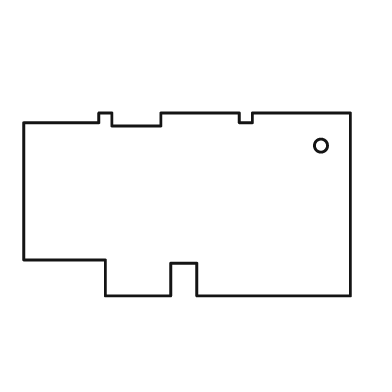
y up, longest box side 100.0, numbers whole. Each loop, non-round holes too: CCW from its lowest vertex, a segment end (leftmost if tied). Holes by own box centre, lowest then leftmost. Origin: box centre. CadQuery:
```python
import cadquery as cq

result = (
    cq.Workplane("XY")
    .moveTo(-25.0, -28.0)
    .lineTo(-5.0, -28.0)
    .lineTo(-5.0, -18.0)
    .lineTo(3.0, -18.0)
    .lineTo(3.0, -28.0)
    .lineTo(50.0, -28.0)
    .lineTo(50.0, 28.0)
    .lineTo(20.0, 28.0)
    .lineTo(20.0, 25.0)
    .lineTo(16.0, 25.0)
    .lineTo(16.0, 28.0)
    .lineTo(-8.0, 28.0)
    .lineTo(-8.0, 24.0)
    .lineTo(-23.0, 24.0)
    .lineTo(-23.0, 28.0)
    .lineTo(-27.0, 28.0)
    .lineTo(-27.0, 25.0)
    .lineTo(-50.0, 25.0)
    .lineTo(-50.0, -17.0)
    .lineTo(-25.0, -17.0)
    .close()
    .moveTo(41.0, 18.0)
    .circle(2.0)
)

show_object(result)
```